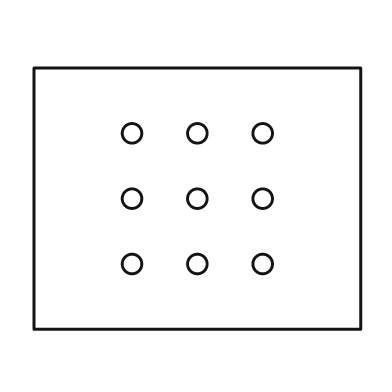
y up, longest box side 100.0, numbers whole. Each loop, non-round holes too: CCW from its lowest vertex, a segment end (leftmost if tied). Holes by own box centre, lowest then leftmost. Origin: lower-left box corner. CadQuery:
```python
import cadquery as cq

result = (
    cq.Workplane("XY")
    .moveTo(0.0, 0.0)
    .lineTo(100.0, 0.0)
    .lineTo(100.0, 80.0)
    .lineTo(0.0, 80.0)
    .close()
    .moveTo(30.0, 20.0)
    .circle(3.0)
    .moveTo(50.0, 20.0)
    .circle(3.0)
    .moveTo(70.0, 20.0)
    .circle(3.0)
    .moveTo(30.0, 40.0)
    .circle(3.0)
    .moveTo(50.0, 40.0)
    .circle(3.0)
    .moveTo(70.0, 40.0)
    .circle(3.0)
    .moveTo(30.0, 60.0)
    .circle(3.0)
    .moveTo(50.0, 60.0)
    .circle(3.0)
    .moveTo(70.0, 60.0)
    .circle(3.0)
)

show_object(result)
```